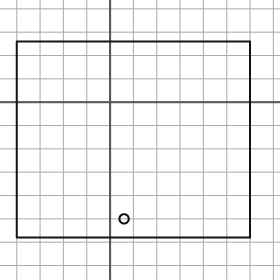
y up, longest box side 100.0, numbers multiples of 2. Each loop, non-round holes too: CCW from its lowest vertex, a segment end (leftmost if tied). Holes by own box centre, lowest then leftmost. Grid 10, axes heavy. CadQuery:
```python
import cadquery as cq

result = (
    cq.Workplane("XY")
    .moveTo(-40.0, -58.0)
    .lineTo(60.0, -58.0)
    .lineTo(60.0, 26.0)
    .lineTo(-40.0, 26.0)
    .close()
    .moveTo(6.0, -50.0)
    .circle(2.0)
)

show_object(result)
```